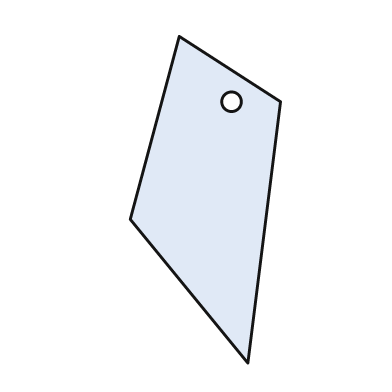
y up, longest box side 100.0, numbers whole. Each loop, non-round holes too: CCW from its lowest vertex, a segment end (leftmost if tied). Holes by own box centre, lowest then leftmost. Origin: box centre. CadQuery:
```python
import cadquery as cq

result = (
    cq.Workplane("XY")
    .moveTo(13.0, -50.0)
    .lineTo(23.0, 30.0)
    .lineTo(-8.0, 50.0)
    .lineTo(-23.0, -6.0)
    .close()
    .moveTo(8.0, 30.0)
    .circle(3.0)
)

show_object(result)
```